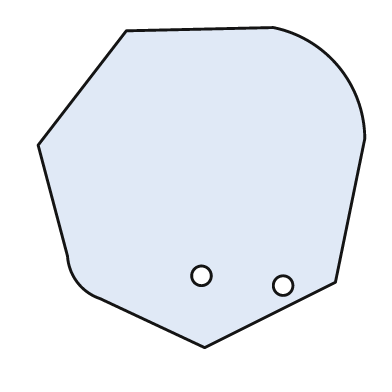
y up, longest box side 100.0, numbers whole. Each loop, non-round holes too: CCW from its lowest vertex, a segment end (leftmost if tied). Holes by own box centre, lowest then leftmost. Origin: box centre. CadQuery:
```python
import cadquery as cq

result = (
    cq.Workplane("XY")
    .moveTo(1.0, -49.0)
    .lineTo(41.0, -29.0)
    .lineTo(50.0, 15.0)
    .threePointArc((42.0, 37.0), (22.0, 49.0))
    .lineTo(-23.0, 48.0)
    .lineTo(-50.0, 13.0)
    .lineTo(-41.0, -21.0)
    .threePointArc((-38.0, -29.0), (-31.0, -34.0))
    .close()
    .moveTo(25.0, -30.0)
    .circle(3.0)
    .moveTo(0.0, -27.0)
    .circle(3.0)
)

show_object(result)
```